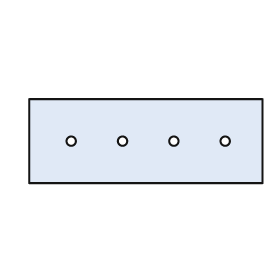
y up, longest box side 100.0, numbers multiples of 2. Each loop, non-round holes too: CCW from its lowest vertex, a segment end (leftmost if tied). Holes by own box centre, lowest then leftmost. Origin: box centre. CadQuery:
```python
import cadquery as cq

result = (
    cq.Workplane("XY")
    .moveTo(-50.0, -18.0)
    .lineTo(50.0, -18.0)
    .lineTo(50.0, 18.0)
    .lineTo(-50.0, 18.0)
    .close()
    .moveTo(-32.0, 0.0)
    .circle(2.0)
    .moveTo(-10.0, 0.0)
    .circle(2.0)
    .moveTo(12.0, 0.0)
    .circle(2.0)
    .moveTo(34.0, 0.0)
    .circle(2.0)
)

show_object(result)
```